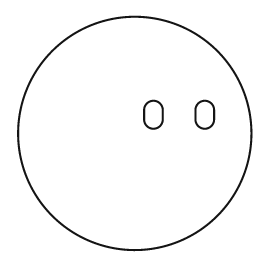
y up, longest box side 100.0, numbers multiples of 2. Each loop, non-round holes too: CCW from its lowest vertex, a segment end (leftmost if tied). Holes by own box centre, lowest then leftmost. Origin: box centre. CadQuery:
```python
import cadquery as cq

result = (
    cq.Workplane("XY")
    .moveTo(0.0, 0.0)
    .circle(50.0)
    .moveTo(4.0, 6.0)
    .threePointArc((8.0, 2.0), (12.0, 6.0))
    .lineTo(12.0, 10.0)
    .threePointArc((8.0, 14.0), (4.0, 10.0))
    .close()
    .moveTo(26.0, 6.0)
    .threePointArc((30.0, 2.0), (34.0, 6.0))
    .lineTo(34.0, 10.0)
    .threePointArc((30.0, 14.0), (26.0, 10.0))
    .close()
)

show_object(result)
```